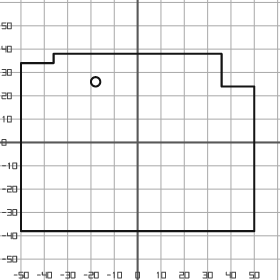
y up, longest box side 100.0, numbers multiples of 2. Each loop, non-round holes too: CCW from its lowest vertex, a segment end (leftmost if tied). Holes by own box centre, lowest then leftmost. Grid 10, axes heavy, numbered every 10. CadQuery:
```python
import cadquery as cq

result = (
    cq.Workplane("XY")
    .moveTo(-50.0, -38.0)
    .lineTo(50.0, -38.0)
    .lineTo(50.0, 24.0)
    .lineTo(36.0, 24.0)
    .lineTo(36.0, 38.0)
    .lineTo(-36.0, 38.0)
    .lineTo(-36.0, 34.0)
    .lineTo(-50.0, 34.0)
    .close()
    .moveTo(-18.0, 26.0)
    .circle(2.0)
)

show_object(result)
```